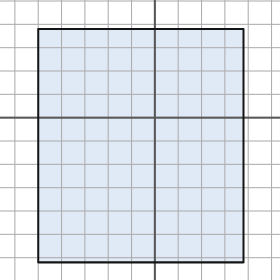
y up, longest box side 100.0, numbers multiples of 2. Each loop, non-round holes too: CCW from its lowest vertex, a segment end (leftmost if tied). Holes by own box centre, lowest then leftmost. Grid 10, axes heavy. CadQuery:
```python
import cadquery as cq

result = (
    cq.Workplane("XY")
    .moveTo(-50.0, -62.0)
    .lineTo(38.0, -62.0)
    .lineTo(38.0, 38.0)
    .lineTo(-50.0, 38.0)
    .close()
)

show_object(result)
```